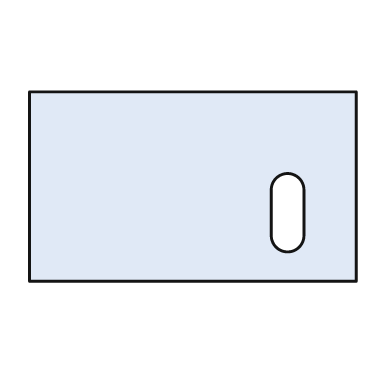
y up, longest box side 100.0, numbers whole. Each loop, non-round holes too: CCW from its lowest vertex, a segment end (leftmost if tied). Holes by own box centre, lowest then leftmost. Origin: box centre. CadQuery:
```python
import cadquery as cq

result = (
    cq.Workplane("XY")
    .moveTo(-50.0, -29.0)
    .lineTo(50.0, -29.0)
    .lineTo(50.0, 29.0)
    .lineTo(-50.0, 29.0)
    .close()
    .moveTo(24.0, -15.0)
    .threePointArc((29.0, -20.0), (34.0, -15.0))
    .lineTo(34.0, -1.0)
    .threePointArc((29.0, 4.0), (24.0, -1.0))
    .close()
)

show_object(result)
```